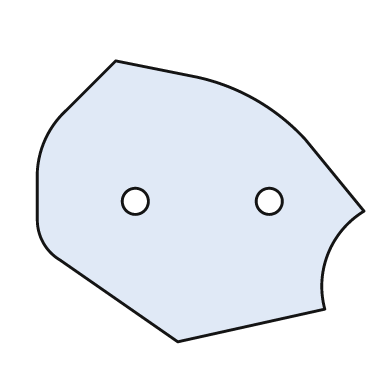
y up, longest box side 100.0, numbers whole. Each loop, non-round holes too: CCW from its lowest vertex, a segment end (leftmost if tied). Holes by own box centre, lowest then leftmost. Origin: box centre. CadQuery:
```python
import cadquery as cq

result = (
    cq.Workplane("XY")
    .moveTo(-7.0, -43.0)
    .lineTo(38.0, -33.0)
    .threePointArc((39.0, -16.0), (50.0, -3.0))
    .lineTo(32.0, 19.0)
    .threePointArc((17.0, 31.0), (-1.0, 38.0))
    .lineTo(-26.0, 43.0)
    .lineTo(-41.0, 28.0)
    .threePointArc((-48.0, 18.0), (-50.0, 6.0))
    .lineTo(-50.0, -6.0)
    .threePointArc((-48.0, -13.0), (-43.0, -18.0))
    .close()
    .moveTo(-20.0, 0.0)
    .circle(4.0)
    .moveTo(21.0, 0.0)
    .circle(4.0)
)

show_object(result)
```